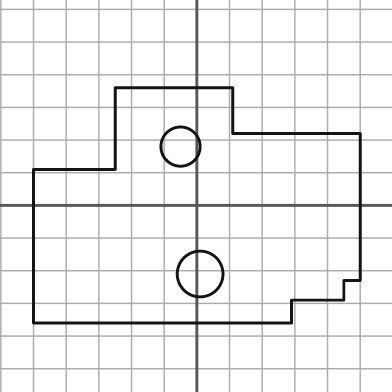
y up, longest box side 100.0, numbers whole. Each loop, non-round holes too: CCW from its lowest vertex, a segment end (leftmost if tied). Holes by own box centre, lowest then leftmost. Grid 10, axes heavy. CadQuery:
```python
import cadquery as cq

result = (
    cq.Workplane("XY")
    .moveTo(-50.0, -36.0)
    .lineTo(29.0, -36.0)
    .lineTo(29.0, -29.0)
    .lineTo(45.0, -29.0)
    .lineTo(45.0, -23.0)
    .lineTo(50.0, -23.0)
    .lineTo(50.0, 22.0)
    .lineTo(11.0, 22.0)
    .lineTo(11.0, 36.0)
    .lineTo(-25.0, 36.0)
    .lineTo(-25.0, 11.0)
    .lineTo(-50.0, 11.0)
    .close()
    .moveTo(1.0, -21.0)
    .circle(7.0)
    .moveTo(-5.0, 18.0)
    .circle(6.0)
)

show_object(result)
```